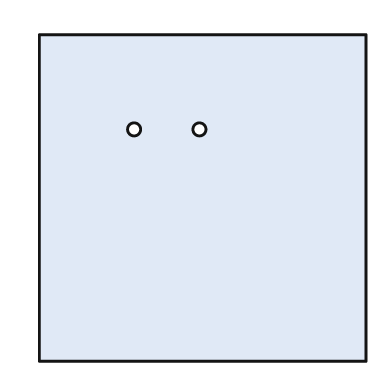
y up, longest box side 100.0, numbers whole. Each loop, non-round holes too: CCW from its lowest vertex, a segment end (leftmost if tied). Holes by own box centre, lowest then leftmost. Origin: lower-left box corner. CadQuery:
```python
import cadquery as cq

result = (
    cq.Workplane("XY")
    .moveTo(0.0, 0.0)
    .lineTo(100.0, 0.0)
    .lineTo(100.0, 100.0)
    .lineTo(0.0, 100.0)
    .close()
    .moveTo(29.0, 71.0)
    .circle(2.0)
    .moveTo(49.0, 71.0)
    .circle(2.0)
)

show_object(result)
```